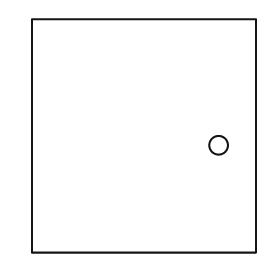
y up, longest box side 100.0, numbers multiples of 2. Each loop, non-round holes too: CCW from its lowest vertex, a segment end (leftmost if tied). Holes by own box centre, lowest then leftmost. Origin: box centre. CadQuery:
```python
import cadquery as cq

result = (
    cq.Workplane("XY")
    .moveTo(-48.0, -50.0)
    .lineTo(48.0, -50.0)
    .lineTo(48.0, 50.0)
    .lineTo(-48.0, 50.0)
    .close()
    .moveTo(32.0, -4.0)
    .circle(4.0)
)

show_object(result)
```